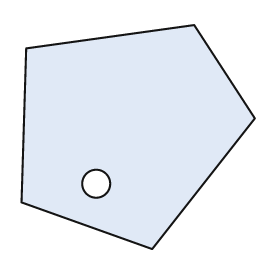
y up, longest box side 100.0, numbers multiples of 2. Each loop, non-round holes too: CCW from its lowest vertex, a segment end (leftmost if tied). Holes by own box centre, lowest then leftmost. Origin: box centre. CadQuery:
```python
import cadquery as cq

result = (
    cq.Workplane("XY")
    .moveTo(6.0, -48.0)
    .lineTo(50.0, 8.0)
    .lineTo(24.0, 48.0)
    .lineTo(-48.0, 38.0)
    .lineTo(-50.0, -28.0)
    .close()
    .moveTo(-18.0, -20.0)
    .circle(6.0)
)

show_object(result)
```